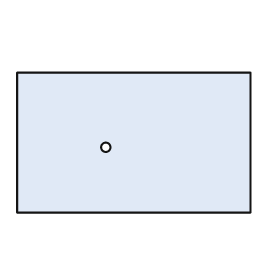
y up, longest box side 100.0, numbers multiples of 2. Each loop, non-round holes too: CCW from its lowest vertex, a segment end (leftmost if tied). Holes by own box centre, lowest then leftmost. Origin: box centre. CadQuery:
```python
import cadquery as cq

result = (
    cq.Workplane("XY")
    .moveTo(-50.0, -30.0)
    .lineTo(50.0, -30.0)
    .lineTo(50.0, 30.0)
    .lineTo(-50.0, 30.0)
    .close()
    .moveTo(-12.0, -2.0)
    .circle(2.0)
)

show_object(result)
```